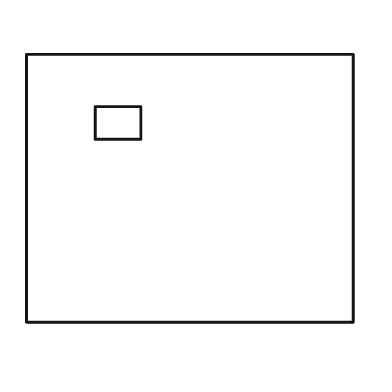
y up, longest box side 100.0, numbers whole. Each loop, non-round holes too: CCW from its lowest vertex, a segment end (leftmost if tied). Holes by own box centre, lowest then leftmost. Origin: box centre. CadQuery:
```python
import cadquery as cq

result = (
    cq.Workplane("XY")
    .moveTo(-50.0, -41.0)
    .lineTo(50.0, -41.0)
    .lineTo(50.0, 41.0)
    .lineTo(-50.0, 41.0)
    .close()
    .moveTo(-29.0, 15.0)
    .lineTo(-15.0, 15.0)
    .lineTo(-15.0, 25.0)
    .lineTo(-29.0, 25.0)
    .close()
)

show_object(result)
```